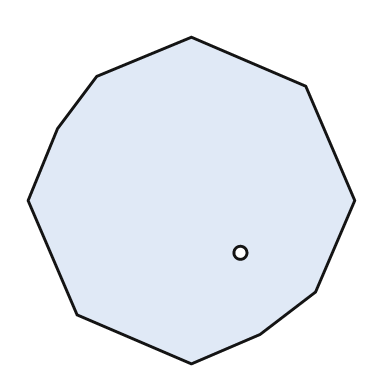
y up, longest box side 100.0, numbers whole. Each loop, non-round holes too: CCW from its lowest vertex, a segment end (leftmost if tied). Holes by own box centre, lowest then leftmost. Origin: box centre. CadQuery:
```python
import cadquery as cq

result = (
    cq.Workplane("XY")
    .moveTo(0.0, -50.0)
    .lineTo(21.0, -41.0)
    .lineTo(38.0, -28.0)
    .lineTo(50.0, 0.0)
    .lineTo(35.0, 35.0)
    .lineTo(0.0, 50.0)
    .lineTo(-29.0, 38.0)
    .lineTo(-41.0, 22.0)
    .lineTo(-50.0, 0.0)
    .lineTo(-35.0, -35.0)
    .close()
    .moveTo(15.0, -16.0)
    .circle(2.0)
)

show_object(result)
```